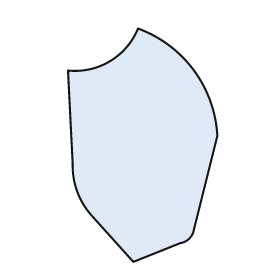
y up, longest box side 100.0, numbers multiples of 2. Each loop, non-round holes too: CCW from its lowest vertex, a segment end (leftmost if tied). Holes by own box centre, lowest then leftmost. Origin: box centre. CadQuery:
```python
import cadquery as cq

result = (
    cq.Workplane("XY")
    .moveTo(-4.0, -50.0)
    .lineTo(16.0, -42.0)
    .threePointArc((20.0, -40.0), (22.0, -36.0))
    .lineTo(32.0, 4.0)
    .threePointArc((22.0, 32.0), (-2.0, 50.0))
    .threePointArc((-14.0, 36.0), (-32.0, 32.0))
    .lineTo(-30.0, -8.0)
    .threePointArc((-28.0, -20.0), (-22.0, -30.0))
    .close()
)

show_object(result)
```